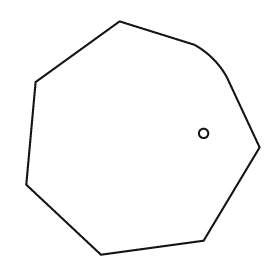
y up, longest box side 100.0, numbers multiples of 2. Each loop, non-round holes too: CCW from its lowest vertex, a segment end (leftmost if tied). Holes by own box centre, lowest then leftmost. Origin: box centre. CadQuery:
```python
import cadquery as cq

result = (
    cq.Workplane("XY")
    .moveTo(-18.0, -50.0)
    .lineTo(26.0, -44.0)
    .lineTo(50.0, -4.0)
    .lineTo(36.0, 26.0)
    .threePointArc((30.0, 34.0), (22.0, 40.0))
    .lineTo(-10.0, 50.0)
    .lineTo(-46.0, 24.0)
    .lineTo(-50.0, -20.0)
    .close()
    .moveTo(26.0, 2.0)
    .circle(2.0)
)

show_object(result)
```